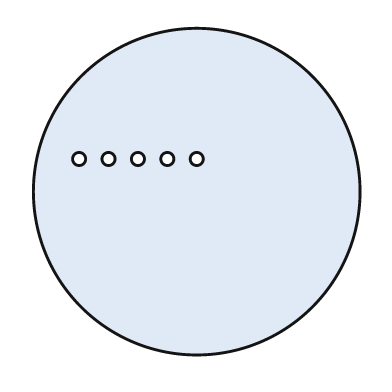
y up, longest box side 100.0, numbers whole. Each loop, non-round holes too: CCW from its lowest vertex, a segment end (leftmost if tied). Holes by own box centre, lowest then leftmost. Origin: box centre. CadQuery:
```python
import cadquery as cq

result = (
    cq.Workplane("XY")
    .moveTo(0.0, 0.0)
    .circle(50.0)
    .moveTo(-36.0, 10.0)
    .circle(2.0)
    .moveTo(-27.0, 10.0)
    .circle(2.0)
    .moveTo(-18.0, 10.0)
    .circle(2.0)
    .moveTo(-9.0, 10.0)
    .circle(2.0)
    .moveTo(0.0, 10.0)
    .circle(2.0)
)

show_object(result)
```